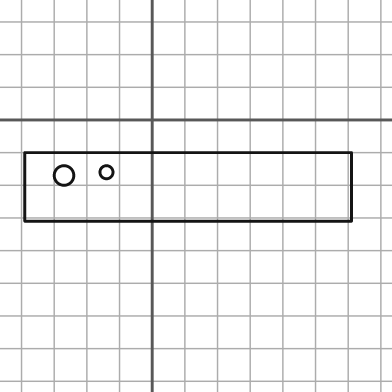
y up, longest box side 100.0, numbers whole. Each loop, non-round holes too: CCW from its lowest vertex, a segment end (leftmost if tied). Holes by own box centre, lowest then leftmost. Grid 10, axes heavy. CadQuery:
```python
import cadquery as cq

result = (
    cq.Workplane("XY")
    .moveTo(-39.0, -31.0)
    .lineTo(61.0, -31.0)
    .lineTo(61.0, -10.0)
    .lineTo(-39.0, -10.0)
    .close()
    .moveTo(-27.0, -17.0)
    .circle(3.0)
    .moveTo(-14.0, -16.0)
    .circle(2.0)
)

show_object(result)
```